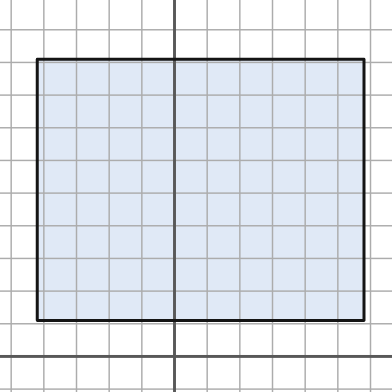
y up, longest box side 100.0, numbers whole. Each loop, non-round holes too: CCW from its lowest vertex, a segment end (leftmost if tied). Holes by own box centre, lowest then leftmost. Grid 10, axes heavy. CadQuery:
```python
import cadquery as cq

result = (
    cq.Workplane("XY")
    .moveTo(-42.0, 11.0)
    .lineTo(58.0, 11.0)
    .lineTo(58.0, 91.0)
    .lineTo(-42.0, 91.0)
    .close()
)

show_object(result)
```